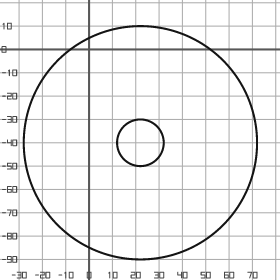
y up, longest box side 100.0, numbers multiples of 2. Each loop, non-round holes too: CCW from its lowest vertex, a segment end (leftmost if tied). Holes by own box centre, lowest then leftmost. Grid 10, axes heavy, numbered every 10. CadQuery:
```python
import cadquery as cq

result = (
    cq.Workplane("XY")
    .moveTo(22.0, -40.0)
    .circle(50.0)
    .moveTo(22.0, -40.0)
    .circle(10.0)
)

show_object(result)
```